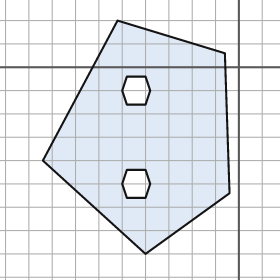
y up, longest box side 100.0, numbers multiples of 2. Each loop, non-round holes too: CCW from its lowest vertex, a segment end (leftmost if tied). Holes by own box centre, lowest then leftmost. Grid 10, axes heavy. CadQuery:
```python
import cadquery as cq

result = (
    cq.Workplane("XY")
    .moveTo(-40.0, -80.0)
    .lineTo(-4.0, -54.0)
    .lineTo(-6.0, 6.0)
    .lineTo(-52.0, 20.0)
    .lineTo(-84.0, -40.0)
    .close()
    .moveTo(-48.0, -56.0)
    .lineTo(-40.0, -56.0)
    .lineTo(-38.0, -50.0)
    .lineTo(-40.0, -44.0)
    .lineTo(-48.0, -44.0)
    .lineTo(-50.0, -50.0)
    .close()
    .moveTo(-48.0, -16.0)
    .lineTo(-40.0, -16.0)
    .lineTo(-38.0, -10.0)
    .lineTo(-40.0, -4.0)
    .lineTo(-48.0, -4.0)
    .lineTo(-50.0, -10.0)
    .close()
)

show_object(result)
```